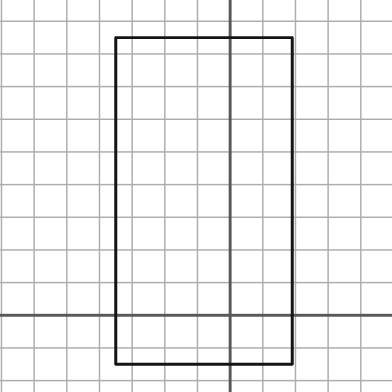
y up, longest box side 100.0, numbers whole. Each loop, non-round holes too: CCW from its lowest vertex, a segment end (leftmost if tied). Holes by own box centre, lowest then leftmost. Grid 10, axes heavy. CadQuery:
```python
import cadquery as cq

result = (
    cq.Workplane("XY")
    .moveTo(-35.0, -15.0)
    .lineTo(19.0, -15.0)
    .lineTo(19.0, 85.0)
    .lineTo(-35.0, 85.0)
    .close()
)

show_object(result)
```